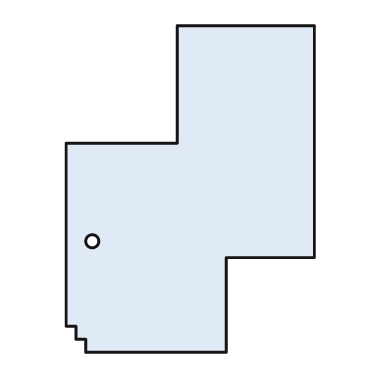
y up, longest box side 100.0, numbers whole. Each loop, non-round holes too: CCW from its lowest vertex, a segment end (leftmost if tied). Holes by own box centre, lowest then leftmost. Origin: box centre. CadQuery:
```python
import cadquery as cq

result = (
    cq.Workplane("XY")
    .moveTo(-32.0, -50.0)
    .lineTo(11.0, -50.0)
    .lineTo(11.0, -21.0)
    .lineTo(38.0, -21.0)
    .lineTo(38.0, 50.0)
    .lineTo(-4.0, 50.0)
    .lineTo(-4.0, 14.0)
    .lineTo(-38.0, 14.0)
    .lineTo(-38.0, -42.0)
    .lineTo(-35.0, -42.0)
    .lineTo(-35.0, -46.0)
    .lineTo(-32.0, -46.0)
    .close()
    .moveTo(-30.0, -16.0)
    .circle(2.0)
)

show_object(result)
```